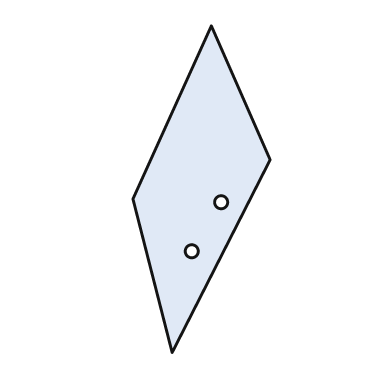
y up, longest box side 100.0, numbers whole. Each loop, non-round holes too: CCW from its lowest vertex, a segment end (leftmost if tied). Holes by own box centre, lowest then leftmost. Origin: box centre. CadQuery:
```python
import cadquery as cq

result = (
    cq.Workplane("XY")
    .moveTo(-9.0, -50.0)
    .lineTo(21.0, 9.0)
    .lineTo(3.0, 50.0)
    .lineTo(-21.0, -3.0)
    .close()
    .moveTo(-3.0, -19.0)
    .circle(2.0)
    .moveTo(6.0, -4.0)
    .circle(2.0)
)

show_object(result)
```